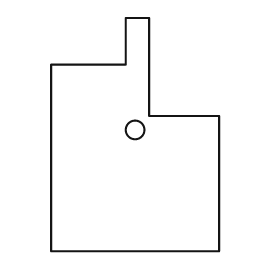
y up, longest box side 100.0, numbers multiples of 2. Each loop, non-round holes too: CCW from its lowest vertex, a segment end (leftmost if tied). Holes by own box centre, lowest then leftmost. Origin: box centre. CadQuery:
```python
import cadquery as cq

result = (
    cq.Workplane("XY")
    .moveTo(-36.0, -50.0)
    .lineTo(36.0, -50.0)
    .lineTo(36.0, 8.0)
    .lineTo(6.0, 8.0)
    .lineTo(6.0, 50.0)
    .lineTo(-4.0, 50.0)
    .lineTo(-4.0, 30.0)
    .lineTo(-36.0, 30.0)
    .close()
    .moveTo(0.0, 2.0)
    .circle(4.0)
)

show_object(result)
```